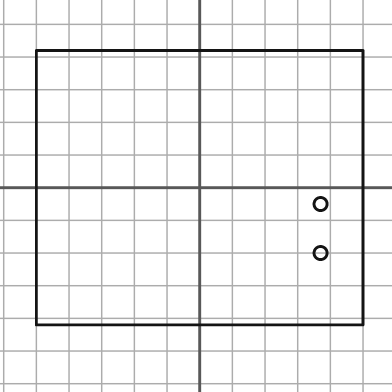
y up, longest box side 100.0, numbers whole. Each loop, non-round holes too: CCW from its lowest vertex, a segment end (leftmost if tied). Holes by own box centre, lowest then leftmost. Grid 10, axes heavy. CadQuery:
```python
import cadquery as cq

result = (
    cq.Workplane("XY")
    .moveTo(-50.0, -42.0)
    .lineTo(50.0, -42.0)
    .lineTo(50.0, 42.0)
    .lineTo(-50.0, 42.0)
    .close()
    .moveTo(37.0, -20.0)
    .circle(2.0)
    .moveTo(37.0, -5.0)
    .circle(2.0)
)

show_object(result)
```